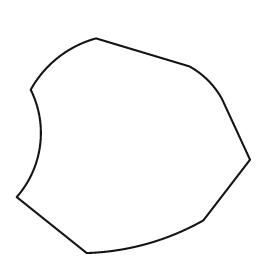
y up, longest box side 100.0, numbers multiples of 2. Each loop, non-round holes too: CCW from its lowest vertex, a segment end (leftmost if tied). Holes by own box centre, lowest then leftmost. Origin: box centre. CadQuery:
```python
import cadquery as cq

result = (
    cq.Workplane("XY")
    .moveTo(-20.0, -46.0)
    .threePointArc((6.0, -42.0), (30.0, -32.0))
    .lineTo(50.0, -6.0)
    .lineTo(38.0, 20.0)
    .threePointArc((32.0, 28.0), (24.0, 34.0))
    .lineTo(-16.0, 46.0)
    .threePointArc((-32.0, 38.0), (-44.0, 24.0))
    .threePointArc((-40.0, 0.0), (-50.0, -22.0))
    .close()
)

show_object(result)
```